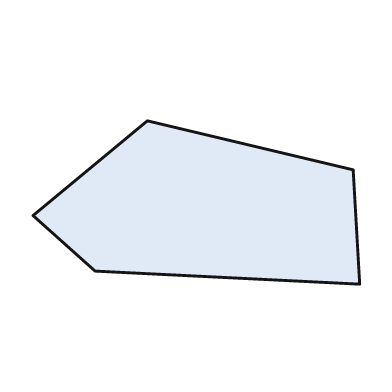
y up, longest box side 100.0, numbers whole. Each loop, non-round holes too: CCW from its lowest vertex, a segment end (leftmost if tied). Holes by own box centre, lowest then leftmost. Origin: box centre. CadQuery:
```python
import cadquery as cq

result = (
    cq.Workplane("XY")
    .moveTo(50.0, -25.0)
    .lineTo(48.0, 10.0)
    .lineTo(-15.0, 25.0)
    .lineTo(-50.0, -4.0)
    .lineTo(-31.0, -21.0)
    .close()
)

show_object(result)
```